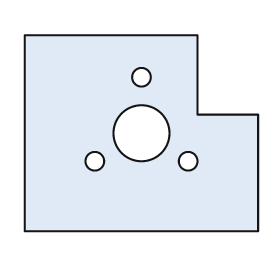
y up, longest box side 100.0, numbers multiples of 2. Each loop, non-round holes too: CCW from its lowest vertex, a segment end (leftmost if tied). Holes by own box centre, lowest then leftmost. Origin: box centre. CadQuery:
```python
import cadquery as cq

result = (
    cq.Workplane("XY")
    .moveTo(-50.0, -42.0)
    .lineTo(50.0, -42.0)
    .lineTo(50.0, 8.0)
    .lineTo(24.0, 8.0)
    .lineTo(24.0, 42.0)
    .lineTo(-50.0, 42.0)
    .close()
    .moveTo(-20.0, -12.0)
    .circle(4.0)
    .moveTo(20.0, -12.0)
    .circle(4.0)
    .moveTo(0.0, 0.0)
    .circle(12.0)
    .moveTo(0.0, 24.0)
    .circle(4.0)
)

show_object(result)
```